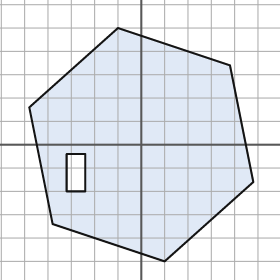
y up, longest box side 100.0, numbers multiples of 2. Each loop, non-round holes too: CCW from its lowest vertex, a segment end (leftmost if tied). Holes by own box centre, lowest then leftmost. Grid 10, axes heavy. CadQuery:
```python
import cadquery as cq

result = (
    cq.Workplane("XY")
    .moveTo(10.0, -50.0)
    .lineTo(48.0, -16.0)
    .lineTo(38.0, 34.0)
    .lineTo(-10.0, 50.0)
    .lineTo(-48.0, 16.0)
    .lineTo(-38.0, -34.0)
    .close()
    .moveTo(-32.0, -20.0)
    .lineTo(-24.0, -20.0)
    .lineTo(-24.0, -4.0)
    .lineTo(-32.0, -4.0)
    .close()
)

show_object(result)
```